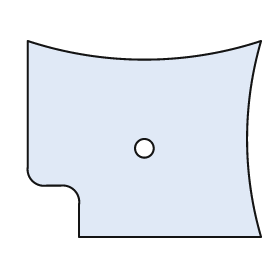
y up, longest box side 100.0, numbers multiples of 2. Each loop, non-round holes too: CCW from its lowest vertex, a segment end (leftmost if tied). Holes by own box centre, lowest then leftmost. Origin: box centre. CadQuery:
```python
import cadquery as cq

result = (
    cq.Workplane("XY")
    .moveTo(-28.0, -42.0)
    .lineTo(50.0, -42.0)
    .threePointArc((44.0, 0.0), (50.0, 42.0))
    .threePointArc((0.0, 34.0), (-50.0, 42.0))
    .lineTo(-50.0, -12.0)
    .threePointArc((-48.0, -18.0), (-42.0, -20.0))
    .lineTo(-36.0, -20.0)
    .threePointArc((-30.0, -22.0), (-28.0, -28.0))
    .close()
    .moveTo(0.0, -4.0)
    .circle(4.0)
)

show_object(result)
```